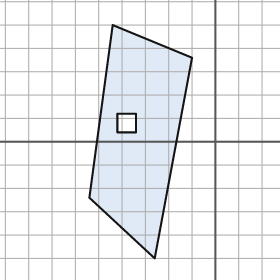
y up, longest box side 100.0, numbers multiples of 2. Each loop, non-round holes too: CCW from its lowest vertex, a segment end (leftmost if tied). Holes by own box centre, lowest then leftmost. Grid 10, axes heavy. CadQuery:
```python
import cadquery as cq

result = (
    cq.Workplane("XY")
    .moveTo(-26.0, -50.0)
    .lineTo(-10.0, 36.0)
    .lineTo(-44.0, 50.0)
    .lineTo(-54.0, -24.0)
    .close()
    .moveTo(-42.0, 4.0)
    .lineTo(-34.0, 4.0)
    .lineTo(-34.0, 12.0)
    .lineTo(-42.0, 12.0)
    .close()
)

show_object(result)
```